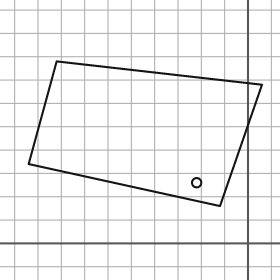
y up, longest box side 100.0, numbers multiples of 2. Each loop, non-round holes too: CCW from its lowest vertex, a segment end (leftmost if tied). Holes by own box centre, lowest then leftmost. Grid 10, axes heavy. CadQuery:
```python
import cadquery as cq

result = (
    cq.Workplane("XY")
    .moveTo(-12.0, 16.0)
    .lineTo(6.0, 68.0)
    .lineTo(-82.0, 78.0)
    .lineTo(-94.0, 34.0)
    .close()
    .moveTo(-22.0, 26.0)
    .circle(2.0)
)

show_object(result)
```